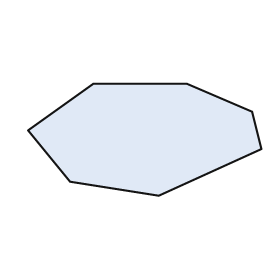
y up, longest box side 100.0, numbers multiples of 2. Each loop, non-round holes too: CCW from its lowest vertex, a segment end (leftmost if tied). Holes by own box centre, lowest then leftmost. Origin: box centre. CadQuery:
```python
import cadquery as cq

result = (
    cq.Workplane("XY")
    .moveTo(6.0, -24.0)
    .lineTo(50.0, -4.0)
    .lineTo(46.0, 12.0)
    .lineTo(18.0, 24.0)
    .lineTo(-22.0, 24.0)
    .lineTo(-50.0, 4.0)
    .lineTo(-32.0, -18.0)
    .close()
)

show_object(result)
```